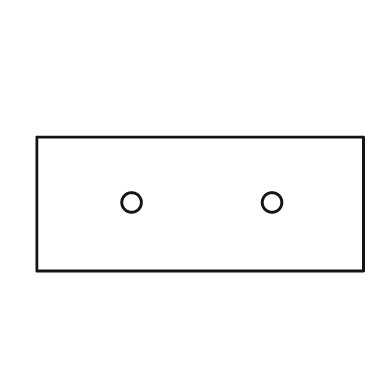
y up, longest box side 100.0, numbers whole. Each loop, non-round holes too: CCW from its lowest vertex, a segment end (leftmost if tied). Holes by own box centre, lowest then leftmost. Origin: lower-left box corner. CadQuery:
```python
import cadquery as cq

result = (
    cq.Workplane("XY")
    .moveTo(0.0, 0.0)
    .lineTo(100.0, 0.0)
    .lineTo(100.0, 41.0)
    .lineTo(0.0, 41.0)
    .close()
    .moveTo(29.0, 21.0)
    .circle(3.0)
    .moveTo(72.0, 21.0)
    .circle(3.0)
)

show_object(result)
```